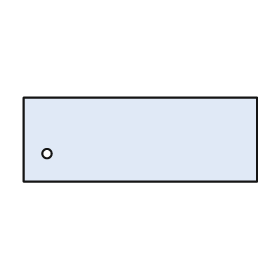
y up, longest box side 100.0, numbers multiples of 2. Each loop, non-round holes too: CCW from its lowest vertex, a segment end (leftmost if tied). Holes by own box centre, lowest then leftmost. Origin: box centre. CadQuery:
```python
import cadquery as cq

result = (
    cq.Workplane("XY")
    .moveTo(-50.0, -18.0)
    .lineTo(50.0, -18.0)
    .lineTo(50.0, 18.0)
    .lineTo(-50.0, 18.0)
    .close()
    .moveTo(-40.0, -6.0)
    .circle(2.0)
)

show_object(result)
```